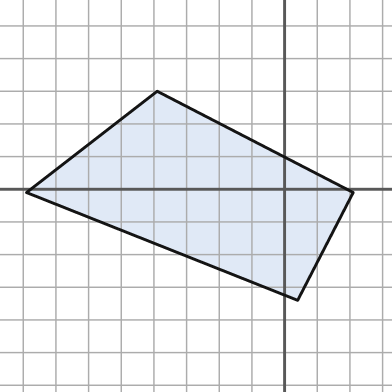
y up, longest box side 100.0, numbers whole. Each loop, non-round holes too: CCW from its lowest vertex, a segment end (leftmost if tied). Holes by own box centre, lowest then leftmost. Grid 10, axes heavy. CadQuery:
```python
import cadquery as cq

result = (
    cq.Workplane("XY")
    .moveTo(4.0, -34.0)
    .lineTo(21.0, -1.0)
    .lineTo(-39.0, 30.0)
    .lineTo(-79.0, -1.0)
    .close()
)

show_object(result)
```